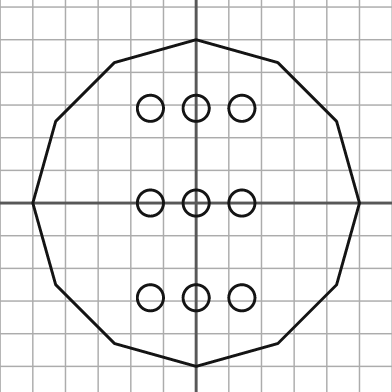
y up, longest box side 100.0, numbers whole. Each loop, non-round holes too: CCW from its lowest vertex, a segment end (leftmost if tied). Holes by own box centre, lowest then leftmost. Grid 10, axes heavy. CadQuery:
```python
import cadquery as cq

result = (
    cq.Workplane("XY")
    .moveTo(0.0, -50.0)
    .lineTo(25.0, -43.0)
    .lineTo(43.0, -25.0)
    .lineTo(50.0, 0.0)
    .lineTo(43.0, 25.0)
    .lineTo(25.0, 43.0)
    .lineTo(0.0, 50.0)
    .lineTo(-25.0, 43.0)
    .lineTo(-43.0, 25.0)
    .lineTo(-50.0, 0.0)
    .lineTo(-43.0, -25.0)
    .lineTo(-25.0, -43.0)
    .close()
    .moveTo(-14.0, -29.0)
    .circle(4.0)
    .moveTo(0.0, -29.0)
    .circle(4.0)
    .moveTo(14.0, -29.0)
    .circle(4.0)
    .moveTo(-14.0, 0.0)
    .circle(4.0)
    .moveTo(0.0, 0.0)
    .circle(4.0)
    .moveTo(14.0, 0.0)
    .circle(4.0)
    .moveTo(-14.0, 29.0)
    .circle(4.0)
    .moveTo(0.0, 29.0)
    .circle(4.0)
    .moveTo(14.0, 29.0)
    .circle(4.0)
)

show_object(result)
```